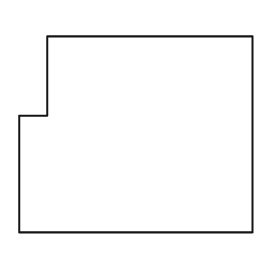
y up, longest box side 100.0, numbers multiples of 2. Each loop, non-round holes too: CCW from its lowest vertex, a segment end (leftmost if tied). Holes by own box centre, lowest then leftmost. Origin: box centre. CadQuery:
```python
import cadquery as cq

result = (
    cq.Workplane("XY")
    .moveTo(-50.0, -42.0)
    .lineTo(50.0, -42.0)
    .lineTo(50.0, 42.0)
    .lineTo(-38.0, 42.0)
    .lineTo(-38.0, 8.0)
    .lineTo(-50.0, 8.0)
    .close()
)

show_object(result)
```